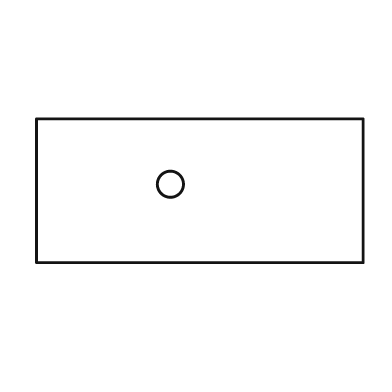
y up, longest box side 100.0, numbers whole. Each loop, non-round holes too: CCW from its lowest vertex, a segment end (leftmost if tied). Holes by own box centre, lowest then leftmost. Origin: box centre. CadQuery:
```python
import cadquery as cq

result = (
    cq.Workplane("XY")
    .moveTo(-50.0, -22.0)
    .lineTo(50.0, -22.0)
    .lineTo(50.0, 22.0)
    .lineTo(-50.0, 22.0)
    .close()
    .moveTo(-9.0, 2.0)
    .circle(4.0)
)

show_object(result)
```